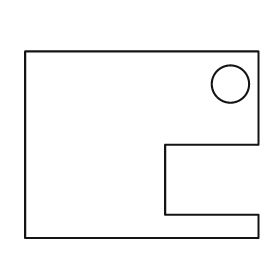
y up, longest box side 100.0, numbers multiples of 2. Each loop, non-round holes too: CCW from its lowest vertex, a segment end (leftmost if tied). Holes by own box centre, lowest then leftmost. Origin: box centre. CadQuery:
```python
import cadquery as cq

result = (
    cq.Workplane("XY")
    .moveTo(-50.0, -40.0)
    .lineTo(50.0, -40.0)
    .lineTo(50.0, -30.0)
    .lineTo(10.0, -30.0)
    .lineTo(10.0, 0.0)
    .lineTo(50.0, 0.0)
    .lineTo(50.0, 40.0)
    .lineTo(-50.0, 40.0)
    .close()
    .moveTo(38.0, 26.0)
    .circle(8.0)
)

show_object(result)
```